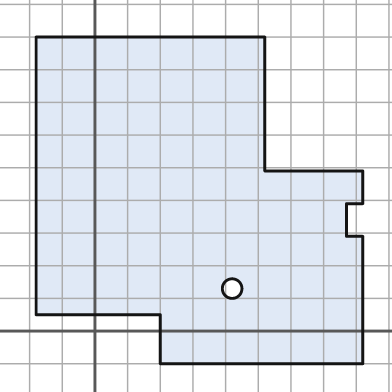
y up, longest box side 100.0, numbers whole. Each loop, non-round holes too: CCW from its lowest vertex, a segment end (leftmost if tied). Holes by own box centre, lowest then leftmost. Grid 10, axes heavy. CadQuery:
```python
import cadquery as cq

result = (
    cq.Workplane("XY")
    .moveTo(20.0, -10.0)
    .lineTo(82.0, -10.0)
    .lineTo(82.0, 29.0)
    .lineTo(77.0, 29.0)
    .lineTo(77.0, 39.0)
    .lineTo(82.0, 39.0)
    .lineTo(82.0, 49.0)
    .lineTo(52.0, 49.0)
    .lineTo(52.0, 90.0)
    .lineTo(-18.0, 90.0)
    .lineTo(-18.0, 5.0)
    .lineTo(20.0, 5.0)
    .close()
    .moveTo(42.0, 13.0)
    .circle(3.0)
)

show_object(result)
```